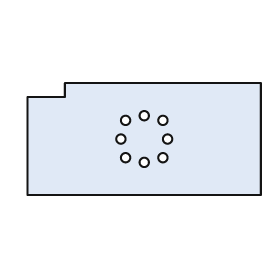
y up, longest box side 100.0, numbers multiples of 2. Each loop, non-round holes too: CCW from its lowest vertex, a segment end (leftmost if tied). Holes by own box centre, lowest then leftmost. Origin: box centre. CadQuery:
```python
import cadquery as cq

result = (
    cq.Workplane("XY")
    .moveTo(-50.0, -24.0)
    .lineTo(50.0, -24.0)
    .lineTo(50.0, 24.0)
    .lineTo(-34.0, 24.0)
    .lineTo(-34.0, 18.0)
    .lineTo(-50.0, 18.0)
    .close()
    .moveTo(0.0, -10.0)
    .circle(2.0)
    .moveTo(-8.0, -8.0)
    .circle(2.0)
    .moveTo(8.0, -8.0)
    .circle(2.0)
    .moveTo(-10.0, 0.0)
    .circle(2.0)
    .moveTo(10.0, 0.0)
    .circle(2.0)
    .moveTo(-8.0, 8.0)
    .circle(2.0)
    .moveTo(8.0, 8.0)
    .circle(2.0)
    .moveTo(0.0, 10.0)
    .circle(2.0)
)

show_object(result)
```